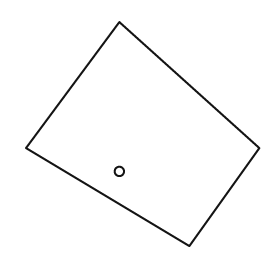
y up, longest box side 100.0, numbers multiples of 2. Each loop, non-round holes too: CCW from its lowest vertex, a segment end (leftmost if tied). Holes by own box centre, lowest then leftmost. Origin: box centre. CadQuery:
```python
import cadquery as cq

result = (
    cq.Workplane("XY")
    .moveTo(20.0, -48.0)
    .lineTo(50.0, -6.0)
    .lineTo(-10.0, 48.0)
    .lineTo(-50.0, -6.0)
    .close()
    .moveTo(-10.0, -16.0)
    .circle(2.0)
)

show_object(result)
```